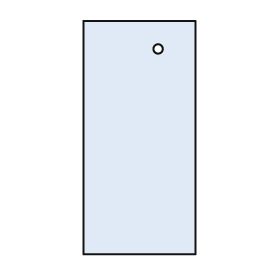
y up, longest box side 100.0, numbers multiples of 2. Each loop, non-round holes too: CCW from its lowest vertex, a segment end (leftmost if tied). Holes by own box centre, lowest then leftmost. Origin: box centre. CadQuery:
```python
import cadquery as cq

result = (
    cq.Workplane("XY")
    .moveTo(-24.0, -50.0)
    .lineTo(24.0, -50.0)
    .lineTo(24.0, 50.0)
    .lineTo(-24.0, 50.0)
    .close()
    .moveTo(8.0, 38.0)
    .circle(2.0)
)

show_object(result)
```